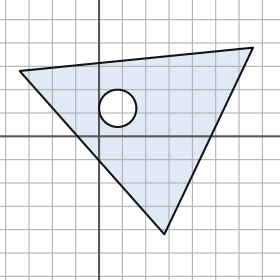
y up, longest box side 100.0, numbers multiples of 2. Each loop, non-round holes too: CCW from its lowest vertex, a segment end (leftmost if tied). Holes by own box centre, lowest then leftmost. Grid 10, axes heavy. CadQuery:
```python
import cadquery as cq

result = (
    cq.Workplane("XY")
    .moveTo(28.0, -42.0)
    .lineTo(66.0, 38.0)
    .lineTo(-34.0, 28.0)
    .close()
    .moveTo(8.0, 12.0)
    .circle(8.0)
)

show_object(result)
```